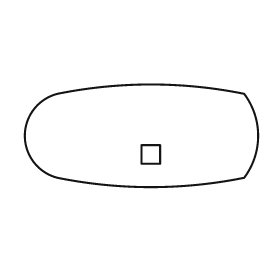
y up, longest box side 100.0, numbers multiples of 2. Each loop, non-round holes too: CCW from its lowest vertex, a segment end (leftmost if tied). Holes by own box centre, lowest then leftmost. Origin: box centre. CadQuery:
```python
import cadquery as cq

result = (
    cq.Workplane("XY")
    .moveTo(-36.0, -18.0)
    .threePointArc((4.0, -22.0), (44.0, -18.0))
    .threePointArc((50.0, 0.0), (44.0, 18.0))
    .threePointArc((4.0, 22.0), (-36.0, 18.0))
    .threePointArc((-50.0, 0.0), (-36.0, -18.0))
    .close()
    .moveTo(0.0, -12.0)
    .lineTo(8.0, -12.0)
    .lineTo(8.0, -4.0)
    .lineTo(0.0, -4.0)
    .close()
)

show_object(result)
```